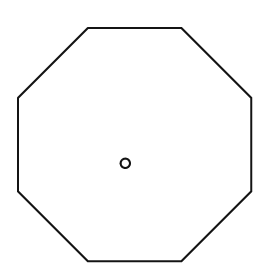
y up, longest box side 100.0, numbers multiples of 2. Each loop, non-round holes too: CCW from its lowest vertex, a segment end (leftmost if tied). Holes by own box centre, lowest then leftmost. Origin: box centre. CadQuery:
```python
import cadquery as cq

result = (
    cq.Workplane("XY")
    .moveTo(-20.0, -50.0)
    .lineTo(20.0, -50.0)
    .lineTo(50.0, -20.0)
    .lineTo(50.0, 20.0)
    .lineTo(20.0, 50.0)
    .lineTo(-20.0, 50.0)
    .lineTo(-50.0, 20.0)
    .lineTo(-50.0, -20.0)
    .close()
    .moveTo(-4.0, -8.0)
    .circle(2.0)
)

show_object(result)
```